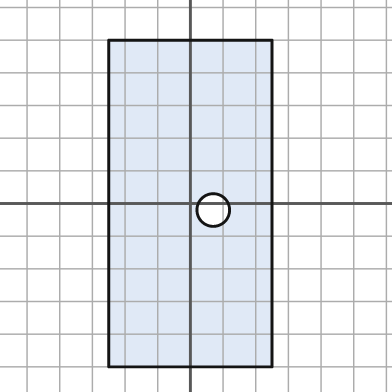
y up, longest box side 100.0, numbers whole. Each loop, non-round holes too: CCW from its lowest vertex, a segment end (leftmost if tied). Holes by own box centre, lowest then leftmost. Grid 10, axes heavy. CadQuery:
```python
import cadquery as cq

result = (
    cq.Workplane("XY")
    .moveTo(-25.0, -50.0)
    .lineTo(25.0, -50.0)
    .lineTo(25.0, 50.0)
    .lineTo(-25.0, 50.0)
    .close()
    .moveTo(7.0, -2.0)
    .circle(5.0)
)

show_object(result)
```